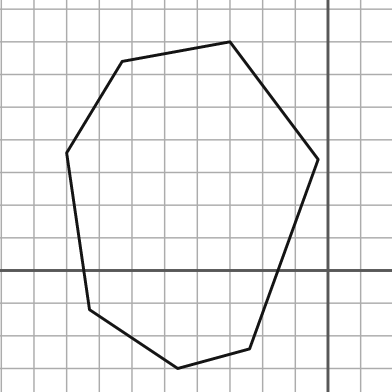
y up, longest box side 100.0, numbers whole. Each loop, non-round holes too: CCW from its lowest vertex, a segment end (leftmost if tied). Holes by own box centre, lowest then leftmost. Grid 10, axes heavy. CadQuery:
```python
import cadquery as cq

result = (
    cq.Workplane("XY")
    .moveTo(-46.0, -30.0)
    .lineTo(-24.0, -24.0)
    .lineTo(-3.0, 34.0)
    .lineTo(-30.0, 70.0)
    .lineTo(-63.0, 64.0)
    .lineTo(-80.0, 36.0)
    .lineTo(-73.0, -12.0)
    .close()
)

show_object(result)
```